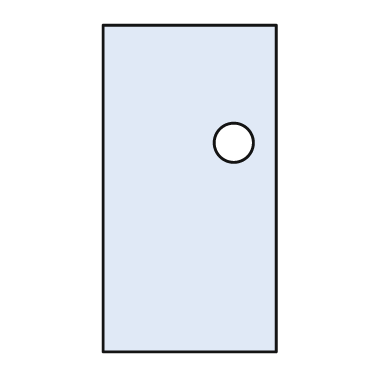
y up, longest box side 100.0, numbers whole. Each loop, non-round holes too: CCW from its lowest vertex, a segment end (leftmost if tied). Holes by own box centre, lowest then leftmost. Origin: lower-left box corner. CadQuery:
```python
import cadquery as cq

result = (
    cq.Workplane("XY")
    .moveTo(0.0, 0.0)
    .lineTo(53.0, 0.0)
    .lineTo(53.0, 100.0)
    .lineTo(0.0, 100.0)
    .close()
    .moveTo(40.0, 64.0)
    .circle(6.0)
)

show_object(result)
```